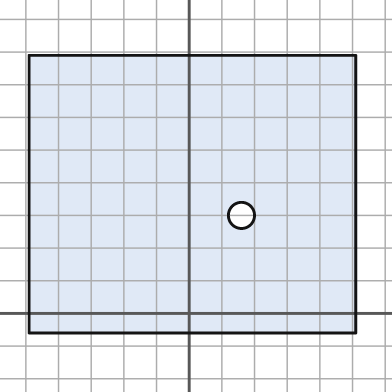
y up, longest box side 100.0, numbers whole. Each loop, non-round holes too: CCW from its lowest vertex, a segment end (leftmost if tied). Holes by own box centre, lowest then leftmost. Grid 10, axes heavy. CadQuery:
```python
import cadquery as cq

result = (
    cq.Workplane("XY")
    .moveTo(-49.0, -6.0)
    .lineTo(51.0, -6.0)
    .lineTo(51.0, 79.0)
    .lineTo(-49.0, 79.0)
    .close()
    .moveTo(16.0, 30.0)
    .circle(4.0)
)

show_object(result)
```